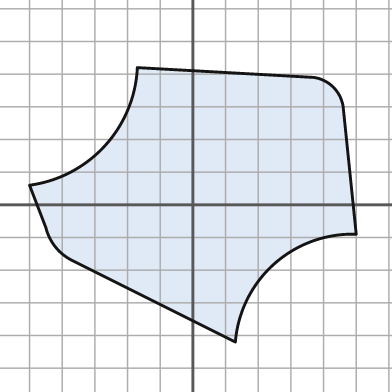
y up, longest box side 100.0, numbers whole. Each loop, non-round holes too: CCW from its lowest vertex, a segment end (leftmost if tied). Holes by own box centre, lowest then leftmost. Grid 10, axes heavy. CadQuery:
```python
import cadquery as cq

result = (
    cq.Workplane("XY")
    .moveTo(13.0, -42.0)
    .threePointArc((25.0, -18.0), (50.0, -9.0))
    .lineTo(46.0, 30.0)
    .threePointArc((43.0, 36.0), (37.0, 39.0))
    .lineTo(-17.0, 42.0)
    .threePointArc((-27.0, 18.0), (-50.0, 6.0))
    .lineTo(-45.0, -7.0)
    .threePointArc((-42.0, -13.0), (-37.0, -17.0))
    .close()
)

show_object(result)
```